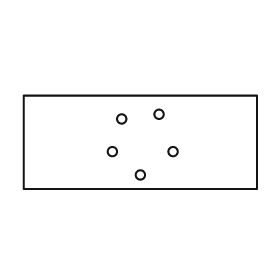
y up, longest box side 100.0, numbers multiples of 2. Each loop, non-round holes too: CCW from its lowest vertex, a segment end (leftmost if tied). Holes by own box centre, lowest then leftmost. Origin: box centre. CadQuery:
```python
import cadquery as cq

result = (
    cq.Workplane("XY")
    .moveTo(-50.0, -20.0)
    .lineTo(50.0, -20.0)
    .lineTo(50.0, 20.0)
    .lineTo(-50.0, 20.0)
    .close()
    .moveTo(0.0, -14.0)
    .circle(2.0)
    .moveTo(-12.0, -4.0)
    .circle(2.0)
    .moveTo(14.0, -4.0)
    .circle(2.0)
    .moveTo(-8.0, 10.0)
    .circle(2.0)
    .moveTo(8.0, 12.0)
    .circle(2.0)
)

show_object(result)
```